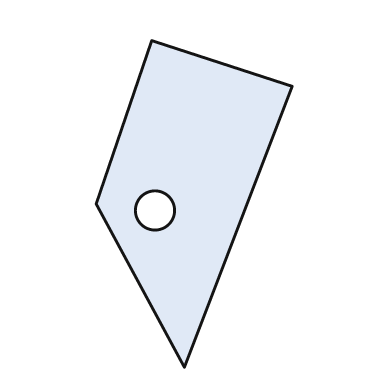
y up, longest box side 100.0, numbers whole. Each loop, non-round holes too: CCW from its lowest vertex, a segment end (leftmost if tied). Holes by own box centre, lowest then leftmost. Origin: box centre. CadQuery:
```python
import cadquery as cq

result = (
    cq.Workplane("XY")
    .moveTo(-3.0, -50.0)
    .lineTo(30.0, 36.0)
    .lineTo(-13.0, 50.0)
    .lineTo(-30.0, 0.0)
    .close()
    .moveTo(-12.0, -2.0)
    .circle(6.0)
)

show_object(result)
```